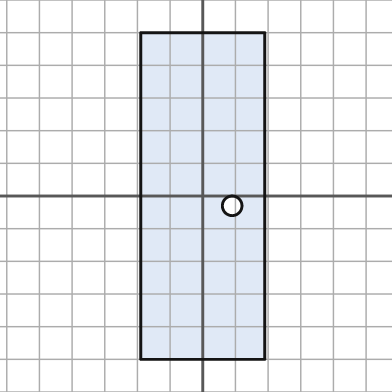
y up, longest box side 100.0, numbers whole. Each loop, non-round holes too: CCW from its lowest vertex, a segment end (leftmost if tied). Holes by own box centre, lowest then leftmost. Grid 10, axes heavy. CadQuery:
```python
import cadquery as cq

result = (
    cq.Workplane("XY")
    .moveTo(-19.0, -50.0)
    .lineTo(19.0, -50.0)
    .lineTo(19.0, 50.0)
    .lineTo(-19.0, 50.0)
    .close()
    .moveTo(9.0, -3.0)
    .circle(3.0)
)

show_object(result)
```